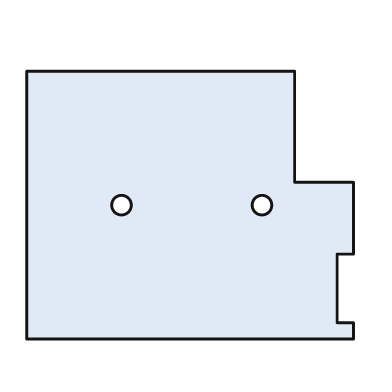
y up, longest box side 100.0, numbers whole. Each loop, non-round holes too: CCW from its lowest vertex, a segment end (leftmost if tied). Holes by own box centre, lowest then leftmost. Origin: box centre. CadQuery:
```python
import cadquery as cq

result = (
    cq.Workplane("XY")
    .moveTo(-50.0, -41.0)
    .lineTo(50.0, -41.0)
    .lineTo(50.0, -36.0)
    .lineTo(45.0, -36.0)
    .lineTo(45.0, -15.0)
    .lineTo(50.0, -15.0)
    .lineTo(50.0, 7.0)
    .lineTo(32.0, 7.0)
    .lineTo(32.0, 41.0)
    .lineTo(-50.0, 41.0)
    .close()
    .moveTo(-21.0, 0.0)
    .circle(3.0)
    .moveTo(22.0, 0.0)
    .circle(3.0)
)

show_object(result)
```